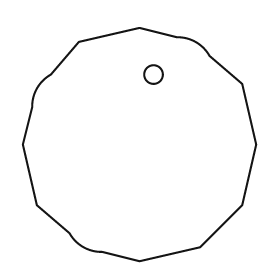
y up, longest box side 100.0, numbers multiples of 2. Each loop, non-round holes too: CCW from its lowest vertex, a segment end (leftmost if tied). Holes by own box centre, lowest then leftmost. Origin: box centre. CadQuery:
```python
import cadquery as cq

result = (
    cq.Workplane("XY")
    .moveTo(0.0, -50.0)
    .lineTo(26.0, -44.0)
    .lineTo(44.0, -26.0)
    .lineTo(50.0, 0.0)
    .lineTo(44.0, 26.0)
    .lineTo(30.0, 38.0)
    .threePointArc((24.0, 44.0), (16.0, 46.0))
    .lineTo(0.0, 50.0)
    .lineTo(-26.0, 44.0)
    .lineTo(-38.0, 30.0)
    .threePointArc((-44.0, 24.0), (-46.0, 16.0))
    .lineTo(-50.0, 0.0)
    .lineTo(-44.0, -26.0)
    .lineTo(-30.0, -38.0)
    .threePointArc((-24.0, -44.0), (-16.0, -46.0))
    .close()
    .moveTo(6.0, 30.0)
    .circle(4.0)
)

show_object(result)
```